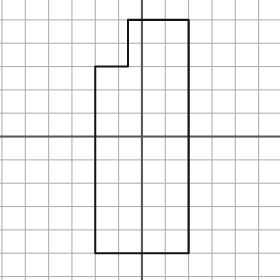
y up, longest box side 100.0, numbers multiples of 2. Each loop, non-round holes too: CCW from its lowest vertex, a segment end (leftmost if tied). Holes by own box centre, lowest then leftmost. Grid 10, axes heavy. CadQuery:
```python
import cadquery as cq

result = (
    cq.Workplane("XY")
    .moveTo(-20.0, -50.0)
    .lineTo(20.0, -50.0)
    .lineTo(20.0, 50.0)
    .lineTo(-6.0, 50.0)
    .lineTo(-6.0, 30.0)
    .lineTo(-20.0, 30.0)
    .close()
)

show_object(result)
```